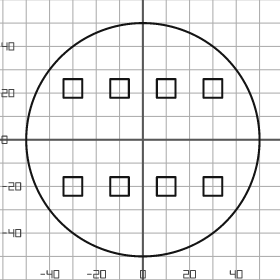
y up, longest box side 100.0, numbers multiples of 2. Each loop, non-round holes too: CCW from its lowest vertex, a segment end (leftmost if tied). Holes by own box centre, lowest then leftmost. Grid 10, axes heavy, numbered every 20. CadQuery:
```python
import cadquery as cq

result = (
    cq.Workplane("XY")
    .moveTo(0.0, 0.0)
    .circle(50.0)
    .moveTo(-34.0, -24.0)
    .lineTo(-26.0, -24.0)
    .lineTo(-26.0, -16.0)
    .lineTo(-34.0, -16.0)
    .close()
    .moveTo(-14.0, -24.0)
    .lineTo(-6.0, -24.0)
    .lineTo(-6.0, -16.0)
    .lineTo(-14.0, -16.0)
    .close()
    .moveTo(6.0, -24.0)
    .lineTo(14.0, -24.0)
    .lineTo(14.0, -16.0)
    .lineTo(6.0, -16.0)
    .close()
    .moveTo(26.0, -24.0)
    .lineTo(34.0, -24.0)
    .lineTo(34.0, -16.0)
    .lineTo(26.0, -16.0)
    .close()
    .moveTo(-34.0, 18.0)
    .lineTo(-26.0, 18.0)
    .lineTo(-26.0, 26.0)
    .lineTo(-34.0, 26.0)
    .close()
    .moveTo(-14.0, 18.0)
    .lineTo(-6.0, 18.0)
    .lineTo(-6.0, 26.0)
    .lineTo(-14.0, 26.0)
    .close()
    .moveTo(6.0, 18.0)
    .lineTo(14.0, 18.0)
    .lineTo(14.0, 26.0)
    .lineTo(6.0, 26.0)
    .close()
    .moveTo(26.0, 18.0)
    .lineTo(34.0, 18.0)
    .lineTo(34.0, 26.0)
    .lineTo(26.0, 26.0)
    .close()
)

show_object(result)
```